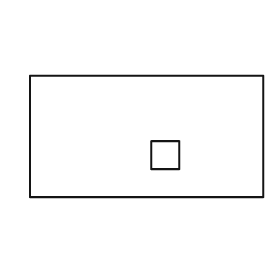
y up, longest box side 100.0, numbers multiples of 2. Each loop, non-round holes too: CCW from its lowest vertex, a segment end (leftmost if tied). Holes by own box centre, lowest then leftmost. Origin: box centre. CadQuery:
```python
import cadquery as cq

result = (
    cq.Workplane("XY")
    .moveTo(-50.0, -26.0)
    .lineTo(50.0, -26.0)
    .lineTo(50.0, 26.0)
    .lineTo(-50.0, 26.0)
    .close()
    .moveTo(2.0, -14.0)
    .lineTo(14.0, -14.0)
    .lineTo(14.0, -2.0)
    .lineTo(2.0, -2.0)
    .close()
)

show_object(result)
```